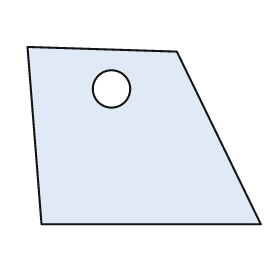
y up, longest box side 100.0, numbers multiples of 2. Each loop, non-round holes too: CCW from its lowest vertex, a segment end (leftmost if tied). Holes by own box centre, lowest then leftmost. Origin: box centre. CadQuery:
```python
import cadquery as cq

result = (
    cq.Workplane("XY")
    .moveTo(-44.0, -38.0)
    .lineTo(50.0, -38.0)
    .lineTo(14.0, 36.0)
    .lineTo(-50.0, 38.0)
    .close()
    .moveTo(-14.0, 20.0)
    .circle(8.0)
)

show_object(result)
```